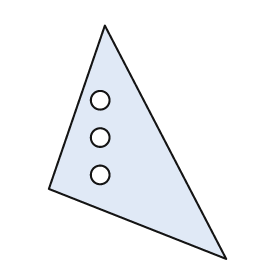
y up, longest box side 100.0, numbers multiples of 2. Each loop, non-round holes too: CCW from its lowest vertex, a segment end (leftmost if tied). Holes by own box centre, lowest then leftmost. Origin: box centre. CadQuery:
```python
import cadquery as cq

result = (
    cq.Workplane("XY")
    .moveTo(38.0, -50.0)
    .lineTo(-14.0, 50.0)
    .lineTo(-38.0, -20.0)
    .close()
    .moveTo(-16.0, -14.0)
    .circle(4.0)
    .moveTo(-16.0, 2.0)
    .circle(4.0)
    .moveTo(-16.0, 18.0)
    .circle(4.0)
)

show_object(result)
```